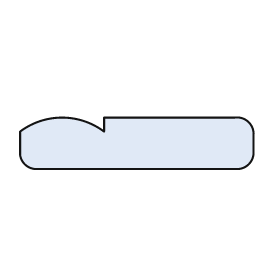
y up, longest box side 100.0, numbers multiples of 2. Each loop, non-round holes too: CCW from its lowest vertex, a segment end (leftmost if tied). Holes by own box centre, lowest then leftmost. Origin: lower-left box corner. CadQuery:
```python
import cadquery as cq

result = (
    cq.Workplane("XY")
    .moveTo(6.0, 0.0)
    .lineTo(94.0, 0.0)
    .threePointArc((98.0, 2.0), (100.0, 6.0))
    .lineTo(100.0, 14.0)
    .threePointArc((98.0, 20.0), (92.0, 22.0))
    .lineTo(36.0, 22.0)
    .lineTo(36.0, 16.0)
    .threePointArc((18.0, 22.0), (0.0, 16.0))
    .lineTo(0.0, 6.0)
    .threePointArc((2.0, 2.0), (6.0, 0.0))
    .close()
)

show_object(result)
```